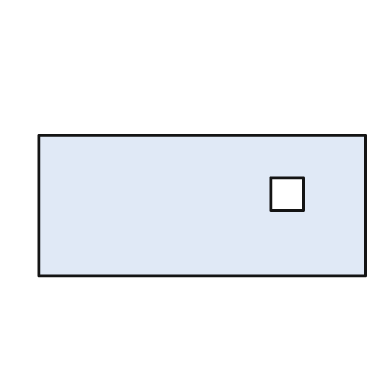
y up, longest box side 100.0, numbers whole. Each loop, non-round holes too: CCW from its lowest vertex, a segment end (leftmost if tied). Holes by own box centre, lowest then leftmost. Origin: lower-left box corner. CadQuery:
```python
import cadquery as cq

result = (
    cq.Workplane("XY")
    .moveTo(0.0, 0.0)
    .lineTo(100.0, 0.0)
    .lineTo(100.0, 43.0)
    .lineTo(0.0, 43.0)
    .close()
    .moveTo(71.0, 20.0)
    .lineTo(81.0, 20.0)
    .lineTo(81.0, 30.0)
    .lineTo(71.0, 30.0)
    .close()
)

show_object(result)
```